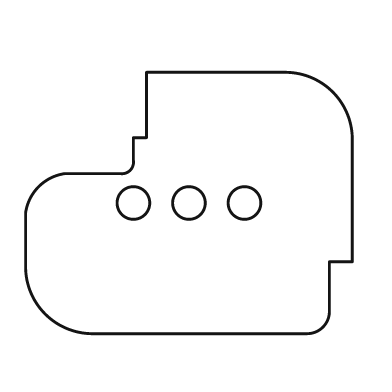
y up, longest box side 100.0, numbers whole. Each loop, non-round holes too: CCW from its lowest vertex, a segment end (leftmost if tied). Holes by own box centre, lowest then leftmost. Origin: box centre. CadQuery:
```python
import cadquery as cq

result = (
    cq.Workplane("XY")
    .moveTo(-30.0, -40.0)
    .lineTo(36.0, -40.0)
    .threePointArc((41.0, -38.0), (43.0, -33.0))
    .lineTo(43.0, -18.0)
    .lineTo(50.0, -18.0)
    .lineTo(50.0, 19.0)
    .threePointArc((44.0, 34.0), (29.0, 40.0))
    .lineTo(-13.0, 40.0)
    .lineTo(-13.0, 20.0)
    .lineTo(-17.0, 20.0)
    .lineTo(-17.0, 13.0)
    .threePointArc((-18.0, 10.0), (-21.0, 9.0))
    .lineTo(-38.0, 9.0)
    .threePointArc((-46.0, 5.0), (-50.0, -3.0))
    .lineTo(-50.0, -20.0)
    .threePointArc((-44.0, -34.0), (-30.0, -40.0))
    .close()
    .moveTo(-17.0, 0.0)
    .circle(5.0)
    .moveTo(0.0, 0.0)
    .circle(5.0)
    .moveTo(17.0, 0.0)
    .circle(5.0)
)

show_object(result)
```